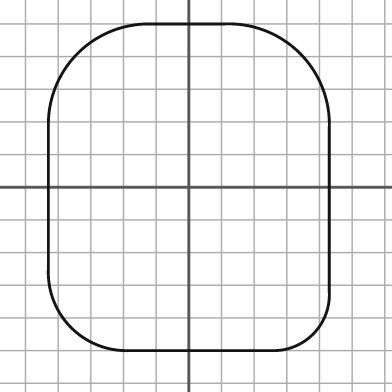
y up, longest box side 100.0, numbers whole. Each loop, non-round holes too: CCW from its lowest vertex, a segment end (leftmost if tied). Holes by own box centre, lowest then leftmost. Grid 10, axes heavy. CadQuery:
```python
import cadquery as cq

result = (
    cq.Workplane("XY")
    .moveTo(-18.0, -50.0)
    .lineTo(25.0, -50.0)
    .threePointArc((38.0, -45.0), (43.0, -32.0))
    .lineTo(43.0, 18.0)
    .threePointArc((34.0, 41.0), (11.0, 50.0))
    .lineTo(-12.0, 50.0)
    .threePointArc((-34.0, 41.0), (-43.0, 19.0))
    .lineTo(-43.0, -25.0)
    .threePointArc((-36.0, -43.0), (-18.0, -50.0))
    .close()
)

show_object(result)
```